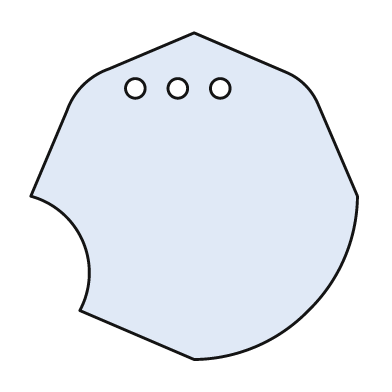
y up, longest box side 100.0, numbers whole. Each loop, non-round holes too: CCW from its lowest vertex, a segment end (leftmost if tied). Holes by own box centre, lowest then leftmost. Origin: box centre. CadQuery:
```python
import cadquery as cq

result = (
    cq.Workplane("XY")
    .moveTo(0.0, -50.0)
    .threePointArc((19.0, -46.0), (35.0, -35.0))
    .threePointArc((46.0, -19.0), (50.0, 0.0))
    .lineTo(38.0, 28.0)
    .threePointArc((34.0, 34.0), (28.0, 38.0))
    .lineTo(0.0, 50.0)
    .lineTo(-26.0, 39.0)
    .threePointArc((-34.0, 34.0), (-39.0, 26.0))
    .lineTo(-50.0, 0.0)
    .threePointArc((-34.0, -14.0), (-35.0, -35.0))
    .close()
    .moveTo(-18.0, 33.0)
    .circle(3.0)
    .moveTo(-5.0, 33.0)
    .circle(3.0)
    .moveTo(8.0, 33.0)
    .circle(3.0)
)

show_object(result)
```